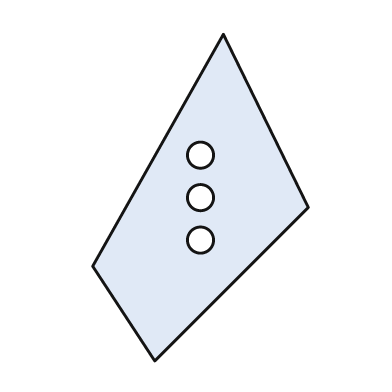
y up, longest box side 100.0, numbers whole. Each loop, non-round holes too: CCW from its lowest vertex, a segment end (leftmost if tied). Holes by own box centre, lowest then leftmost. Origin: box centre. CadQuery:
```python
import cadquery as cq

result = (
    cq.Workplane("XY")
    .moveTo(-14.0, -50.0)
    .lineTo(33.0, -3.0)
    .lineTo(7.0, 50.0)
    .lineTo(-33.0, -21.0)
    .close()
    .moveTo(0.0, -13.0)
    .circle(4.0)
    .moveTo(0.0, 0.0)
    .circle(4.0)
    .moveTo(0.0, 13.0)
    .circle(4.0)
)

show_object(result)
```